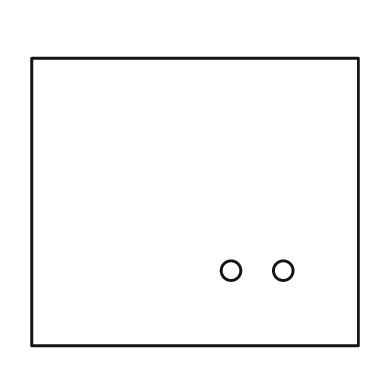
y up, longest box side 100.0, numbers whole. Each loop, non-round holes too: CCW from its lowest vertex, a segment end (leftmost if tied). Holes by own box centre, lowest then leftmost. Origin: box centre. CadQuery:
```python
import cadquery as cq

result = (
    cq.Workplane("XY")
    .moveTo(-50.0, -44.0)
    .lineTo(50.0, -44.0)
    .lineTo(50.0, 44.0)
    .lineTo(-50.0, 44.0)
    .close()
    .moveTo(11.0, -21.0)
    .circle(3.0)
    .moveTo(27.0, -21.0)
    .circle(3.0)
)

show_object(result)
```